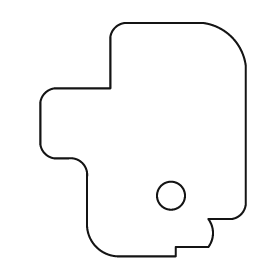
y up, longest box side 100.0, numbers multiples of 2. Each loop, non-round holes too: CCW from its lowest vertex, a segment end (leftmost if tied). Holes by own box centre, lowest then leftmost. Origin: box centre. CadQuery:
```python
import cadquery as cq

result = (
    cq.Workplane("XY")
    .moveTo(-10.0, -50.0)
    .lineTo(14.0, -50.0)
    .lineTo(14.0, -46.0)
    .lineTo(28.0, -46.0)
    .threePointArc((30.0, -40.0), (28.0, -34.0))
    .lineTo(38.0, -34.0)
    .threePointArc((42.0, -32.0), (44.0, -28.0))
    .lineTo(44.0, 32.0)
    .threePointArc((38.0, 44.0), (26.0, 50.0))
    .lineTo(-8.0, 50.0)
    .threePointArc((-12.0, 48.0), (-14.0, 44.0))
    .lineTo(-14.0, 22.0)
    .lineTo(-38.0, 22.0)
    .threePointArc((-42.0, 20.0), (-44.0, 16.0))
    .lineTo(-44.0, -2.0)
    .threePointArc((-42.0, -6.0), (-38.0, -8.0))
    .lineTo(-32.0, -8.0)
    .threePointArc((-26.0, -10.0), (-24.0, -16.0))
    .lineTo(-24.0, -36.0)
    .threePointArc((-20.0, -46.0), (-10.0, -50.0))
    .close()
    .moveTo(12.0, -24.0)
    .circle(6.0)
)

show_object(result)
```